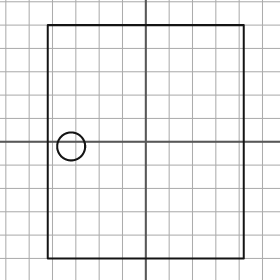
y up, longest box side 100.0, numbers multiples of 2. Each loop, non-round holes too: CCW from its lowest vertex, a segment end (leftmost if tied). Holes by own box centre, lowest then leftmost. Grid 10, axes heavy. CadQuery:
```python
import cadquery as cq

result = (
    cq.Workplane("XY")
    .moveTo(-42.0, -50.0)
    .lineTo(42.0, -50.0)
    .lineTo(42.0, 50.0)
    .lineTo(-42.0, 50.0)
    .close()
    .moveTo(-32.0, -2.0)
    .circle(6.0)
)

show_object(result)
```